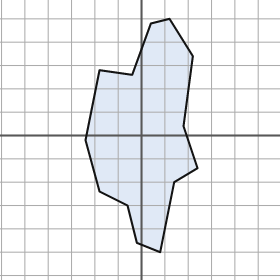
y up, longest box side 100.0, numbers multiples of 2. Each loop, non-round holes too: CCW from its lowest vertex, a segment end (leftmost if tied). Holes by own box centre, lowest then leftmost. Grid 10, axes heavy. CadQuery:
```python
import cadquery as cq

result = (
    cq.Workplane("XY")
    .moveTo(8.0, -50.0)
    .lineTo(14.0, -20.0)
    .lineTo(24.0, -14.0)
    .lineTo(18.0, 4.0)
    .lineTo(22.0, 34.0)
    .lineTo(12.0, 50.0)
    .lineTo(4.0, 48.0)
    .lineTo(-4.0, 26.0)
    .lineTo(-18.0, 28.0)
    .lineTo(-24.0, -2.0)
    .lineTo(-18.0, -24.0)
    .lineTo(-6.0, -30.0)
    .lineTo(-2.0, -46.0)
    .close()
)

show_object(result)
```